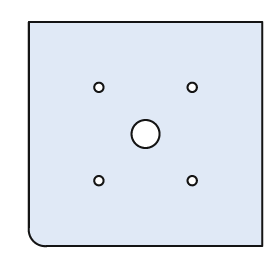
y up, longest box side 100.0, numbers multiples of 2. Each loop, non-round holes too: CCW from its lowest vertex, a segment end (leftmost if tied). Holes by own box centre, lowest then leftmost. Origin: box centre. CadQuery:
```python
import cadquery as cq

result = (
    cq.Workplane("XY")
    .moveTo(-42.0, -48.0)
    .lineTo(50.0, -48.0)
    .lineTo(50.0, 48.0)
    .lineTo(-50.0, 48.0)
    .lineTo(-50.0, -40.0)
    .threePointArc((-48.0, -46.0), (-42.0, -48.0))
    .close()
    .moveTo(-20.0, -20.0)
    .circle(2.0)
    .moveTo(20.0, -20.0)
    .circle(2.0)
    .moveTo(0.0, 0.0)
    .circle(6.0)
    .moveTo(-20.0, 20.0)
    .circle(2.0)
    .moveTo(20.0, 20.0)
    .circle(2.0)
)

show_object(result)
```